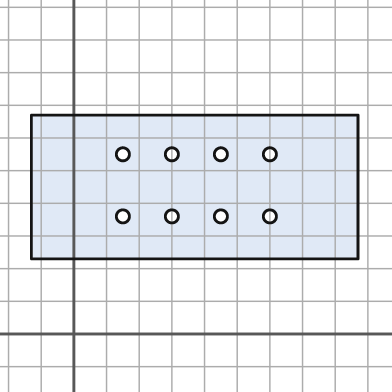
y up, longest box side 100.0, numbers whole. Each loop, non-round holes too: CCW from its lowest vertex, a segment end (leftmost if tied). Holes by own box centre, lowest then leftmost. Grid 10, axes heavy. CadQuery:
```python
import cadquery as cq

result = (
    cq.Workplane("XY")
    .moveTo(-13.0, 23.0)
    .lineTo(87.0, 23.0)
    .lineTo(87.0, 67.0)
    .lineTo(-13.0, 67.0)
    .close()
    .moveTo(15.0, 36.0)
    .circle(2.0)
    .moveTo(30.0, 36.0)
    .circle(2.0)
    .moveTo(45.0, 36.0)
    .circle(2.0)
    .moveTo(60.0, 36.0)
    .circle(2.0)
    .moveTo(15.0, 55.0)
    .circle(2.0)
    .moveTo(30.0, 55.0)
    .circle(2.0)
    .moveTo(45.0, 55.0)
    .circle(2.0)
    .moveTo(60.0, 55.0)
    .circle(2.0)
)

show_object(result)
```